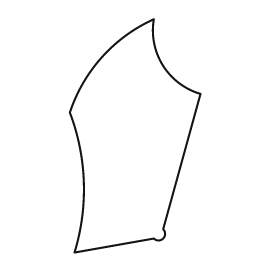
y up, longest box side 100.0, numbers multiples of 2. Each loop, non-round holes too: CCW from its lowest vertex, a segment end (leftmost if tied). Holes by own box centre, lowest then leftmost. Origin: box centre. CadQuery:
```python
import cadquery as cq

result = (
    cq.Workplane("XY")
    .moveTo(-26.0, -50.0)
    .lineTo(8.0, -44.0)
    .threePointArc((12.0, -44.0), (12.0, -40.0))
    .lineTo(28.0, 18.0)
    .threePointArc((12.0, 30.0), (8.0, 50.0))
    .threePointArc((-14.0, 34.0), (-28.0, 10.0))
    .threePointArc((-22.0, -20.0), (-26.0, -50.0))
    .close()
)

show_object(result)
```